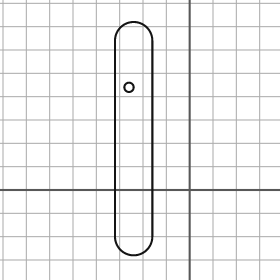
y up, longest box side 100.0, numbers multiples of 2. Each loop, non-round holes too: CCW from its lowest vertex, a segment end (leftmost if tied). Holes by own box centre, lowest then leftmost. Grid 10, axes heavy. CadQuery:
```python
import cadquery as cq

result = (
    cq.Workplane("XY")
    .moveTo(-32.0, -20.0)
    .threePointArc((-24.0, -28.0), (-16.0, -20.0))
    .lineTo(-16.0, 64.0)
    .threePointArc((-24.0, 72.0), (-32.0, 64.0))
    .close()
    .moveTo(-26.0, 44.0)
    .circle(2.0)
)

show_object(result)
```